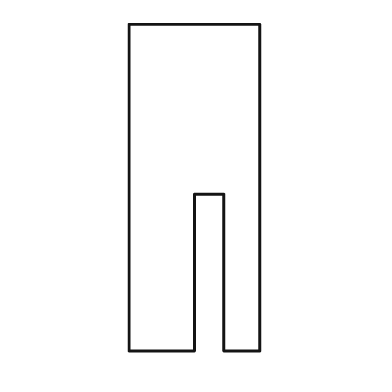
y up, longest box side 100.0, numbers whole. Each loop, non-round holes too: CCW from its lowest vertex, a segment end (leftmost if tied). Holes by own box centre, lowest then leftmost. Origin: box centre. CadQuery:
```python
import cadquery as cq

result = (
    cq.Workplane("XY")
    .moveTo(-20.0, -50.0)
    .lineTo(0.0, -50.0)
    .lineTo(0.0, -2.0)
    .lineTo(9.0, -2.0)
    .lineTo(9.0, -50.0)
    .lineTo(20.0, -50.0)
    .lineTo(20.0, 50.0)
    .lineTo(-20.0, 50.0)
    .close()
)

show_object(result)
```